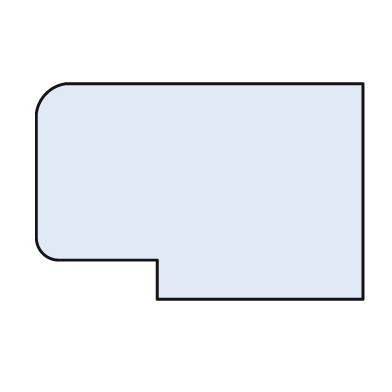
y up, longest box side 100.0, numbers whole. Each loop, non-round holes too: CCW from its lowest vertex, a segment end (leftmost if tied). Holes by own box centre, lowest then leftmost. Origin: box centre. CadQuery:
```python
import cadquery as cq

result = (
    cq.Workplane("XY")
    .moveTo(-13.0, -33.0)
    .lineTo(50.0, -33.0)
    .lineTo(50.0, 33.0)
    .lineTo(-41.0, 33.0)
    .threePointArc((-47.0, 30.0), (-50.0, 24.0))
    .lineTo(-50.0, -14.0)
    .threePointArc((-48.0, -19.0), (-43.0, -21.0))
    .lineTo(-13.0, -21.0)
    .close()
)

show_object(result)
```